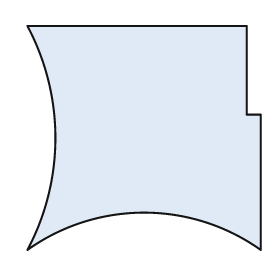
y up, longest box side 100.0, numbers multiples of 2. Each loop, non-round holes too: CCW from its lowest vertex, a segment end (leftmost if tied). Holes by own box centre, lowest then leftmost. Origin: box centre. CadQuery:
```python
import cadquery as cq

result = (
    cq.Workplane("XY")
    .moveTo(-50.0, -48.0)
    .threePointArc((0.0, -32.0), (50.0, -48.0))
    .lineTo(50.0, 10.0)
    .lineTo(44.0, 10.0)
    .lineTo(44.0, 48.0)
    .lineTo(-50.0, 48.0)
    .threePointArc((-38.0, 0.0), (-50.0, -48.0))
    .close()
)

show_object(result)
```